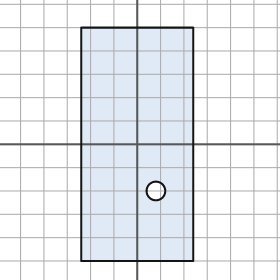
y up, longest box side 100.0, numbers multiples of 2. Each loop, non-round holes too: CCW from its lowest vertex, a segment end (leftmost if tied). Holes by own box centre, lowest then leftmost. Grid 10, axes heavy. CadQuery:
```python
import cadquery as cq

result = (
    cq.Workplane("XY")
    .moveTo(-24.0, -50.0)
    .lineTo(24.0, -50.0)
    .lineTo(24.0, 50.0)
    .lineTo(-24.0, 50.0)
    .close()
    .moveTo(8.0, -20.0)
    .circle(4.0)
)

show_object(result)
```